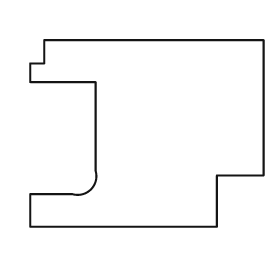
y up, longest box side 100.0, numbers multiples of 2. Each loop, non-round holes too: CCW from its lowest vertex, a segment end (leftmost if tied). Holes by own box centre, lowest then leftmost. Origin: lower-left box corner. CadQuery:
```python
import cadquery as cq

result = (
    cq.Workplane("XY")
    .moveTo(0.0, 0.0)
    .lineTo(80.0, 0.0)
    .lineTo(80.0, 22.0)
    .lineTo(100.0, 22.0)
    .lineTo(100.0, 80.0)
    .lineTo(6.0, 80.0)
    .lineTo(6.0, 70.0)
    .lineTo(0.0, 70.0)
    .lineTo(0.0, 62.0)
    .lineTo(28.0, 62.0)
    .lineTo(28.0, 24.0)
    .threePointArc((26.0, 16.0), (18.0, 14.0))
    .lineTo(0.0, 14.0)
    .close()
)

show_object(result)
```